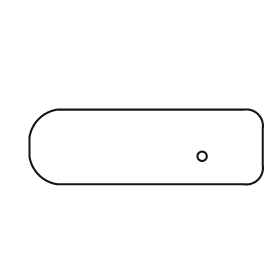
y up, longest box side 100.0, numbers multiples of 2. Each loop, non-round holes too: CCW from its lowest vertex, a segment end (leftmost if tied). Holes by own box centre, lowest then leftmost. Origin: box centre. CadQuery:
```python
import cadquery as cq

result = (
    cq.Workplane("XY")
    .moveTo(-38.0, -16.0)
    .lineTo(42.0, -16.0)
    .threePointArc((48.0, -14.0), (50.0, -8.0))
    .lineTo(50.0, 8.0)
    .threePointArc((48.0, 14.0), (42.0, 16.0))
    .lineTo(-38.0, 16.0)
    .threePointArc((-46.0, 12.0), (-50.0, 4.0))
    .lineTo(-50.0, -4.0)
    .threePointArc((-46.0, -12.0), (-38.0, -16.0))
    .close()
    .moveTo(24.0, -4.0)
    .circle(2.0)
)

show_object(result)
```